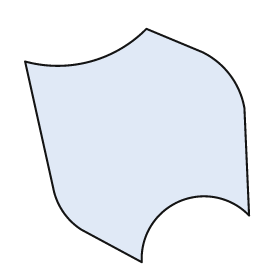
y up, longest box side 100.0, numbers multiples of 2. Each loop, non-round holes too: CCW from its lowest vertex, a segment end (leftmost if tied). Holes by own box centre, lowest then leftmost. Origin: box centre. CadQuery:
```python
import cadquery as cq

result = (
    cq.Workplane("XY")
    .moveTo(2.0, -50.0)
    .threePointArc((18.0, -24.0), (48.0, -30.0))
    .lineTo(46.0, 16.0)
    .threePointArc((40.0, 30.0), (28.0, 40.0))
    .lineTo(4.0, 50.0)
    .threePointArc((-20.0, 36.0), (-48.0, 36.0))
    .lineTo(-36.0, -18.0)
    .threePointArc((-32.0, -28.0), (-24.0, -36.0))
    .close()
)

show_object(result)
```